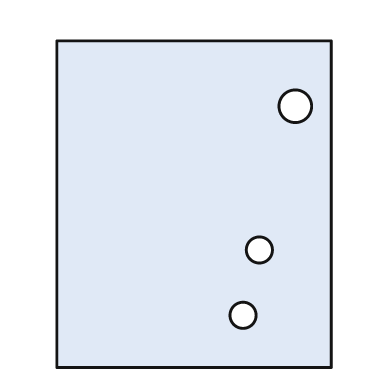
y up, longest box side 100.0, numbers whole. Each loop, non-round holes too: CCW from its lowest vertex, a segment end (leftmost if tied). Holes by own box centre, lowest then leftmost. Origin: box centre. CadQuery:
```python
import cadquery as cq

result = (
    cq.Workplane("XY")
    .moveTo(-42.0, -50.0)
    .lineTo(42.0, -50.0)
    .lineTo(42.0, 50.0)
    .lineTo(-42.0, 50.0)
    .close()
    .moveTo(15.0, -34.0)
    .circle(4.0)
    .moveTo(20.0, -14.0)
    .circle(4.0)
    .moveTo(31.0, 30.0)
    .circle(5.0)
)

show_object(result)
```